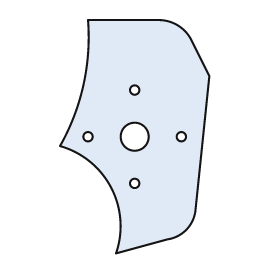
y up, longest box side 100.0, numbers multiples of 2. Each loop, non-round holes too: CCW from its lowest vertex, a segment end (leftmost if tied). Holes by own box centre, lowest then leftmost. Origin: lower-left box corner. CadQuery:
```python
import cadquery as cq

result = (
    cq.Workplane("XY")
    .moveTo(24.0, 0.0)
    .lineTo(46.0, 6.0)
    .threePointArc((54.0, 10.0), (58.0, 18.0))
    .lineTo(64.0, 76.0)
    .lineTo(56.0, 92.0)
    .threePointArc((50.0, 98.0), (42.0, 100.0))
    .lineTo(12.0, 100.0)
    .threePointArc((10.0, 72.0), (0.0, 46.0))
    .threePointArc((22.0, 28.0), (24.0, 0.0))
    .close()
    .moveTo(32.0, 30.0)
    .circle(2.0)
    .moveTo(12.0, 50.0)
    .circle(2.0)
    .moveTo(32.0, 50.0)
    .circle(6.0)
    .moveTo(52.0, 50.0)
    .circle(2.0)
    .moveTo(32.0, 70.0)
    .circle(2.0)
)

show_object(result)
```